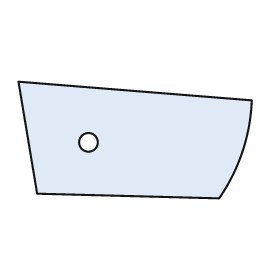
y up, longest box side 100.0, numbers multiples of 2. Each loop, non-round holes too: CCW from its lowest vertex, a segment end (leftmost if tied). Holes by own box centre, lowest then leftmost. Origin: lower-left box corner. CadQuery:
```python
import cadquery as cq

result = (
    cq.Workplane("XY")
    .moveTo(86.0, 0.0)
    .threePointArc((96.0, 20.0), (100.0, 42.0))
    .lineTo(0.0, 50.0)
    .lineTo(8.0, 2.0)
    .close()
    .moveTo(30.0, 24.0)
    .circle(4.0)
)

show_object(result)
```